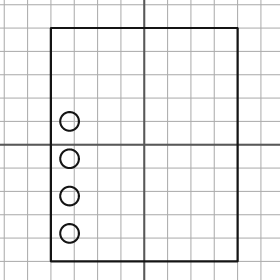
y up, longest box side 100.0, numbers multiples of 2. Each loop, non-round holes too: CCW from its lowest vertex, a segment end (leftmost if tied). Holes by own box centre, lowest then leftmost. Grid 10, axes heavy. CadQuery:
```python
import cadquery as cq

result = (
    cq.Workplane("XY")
    .moveTo(-40.0, -50.0)
    .lineTo(40.0, -50.0)
    .lineTo(40.0, 50.0)
    .lineTo(-40.0, 50.0)
    .close()
    .moveTo(-32.0, -38.0)
    .circle(4.0)
    .moveTo(-32.0, -22.0)
    .circle(4.0)
    .moveTo(-32.0, -6.0)
    .circle(4.0)
    .moveTo(-32.0, 10.0)
    .circle(4.0)
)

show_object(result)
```